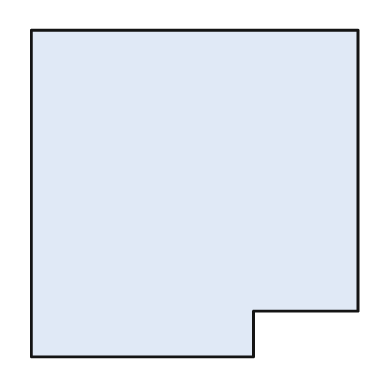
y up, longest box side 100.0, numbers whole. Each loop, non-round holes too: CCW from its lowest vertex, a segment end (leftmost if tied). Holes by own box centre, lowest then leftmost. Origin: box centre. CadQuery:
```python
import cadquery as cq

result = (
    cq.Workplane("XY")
    .moveTo(-50.0, -50.0)
    .lineTo(18.0, -50.0)
    .lineTo(18.0, -36.0)
    .lineTo(50.0, -36.0)
    .lineTo(50.0, 50.0)
    .lineTo(-50.0, 50.0)
    .close()
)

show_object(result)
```